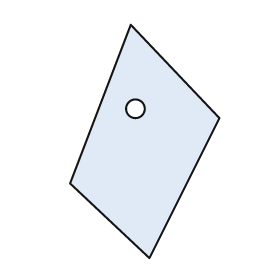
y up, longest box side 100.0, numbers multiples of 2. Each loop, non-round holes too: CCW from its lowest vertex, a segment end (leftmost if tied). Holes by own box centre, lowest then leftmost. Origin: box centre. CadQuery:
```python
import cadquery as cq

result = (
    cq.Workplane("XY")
    .moveTo(2.0, -50.0)
    .lineTo(32.0, 10.0)
    .lineTo(-6.0, 50.0)
    .lineTo(-32.0, -18.0)
    .close()
    .moveTo(-4.0, 14.0)
    .circle(4.0)
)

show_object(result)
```